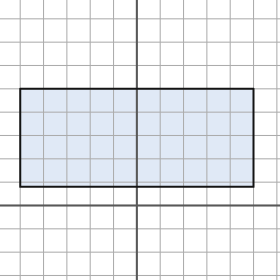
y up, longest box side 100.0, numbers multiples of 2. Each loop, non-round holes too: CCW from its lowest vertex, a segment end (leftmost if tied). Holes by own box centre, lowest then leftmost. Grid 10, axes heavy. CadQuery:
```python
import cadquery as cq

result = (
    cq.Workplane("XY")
    .moveTo(-50.0, 8.0)
    .lineTo(50.0, 8.0)
    .lineTo(50.0, 50.0)
    .lineTo(-50.0, 50.0)
    .close()
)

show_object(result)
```